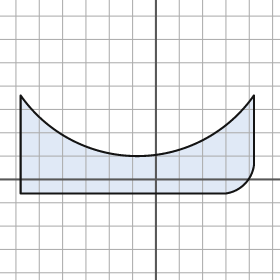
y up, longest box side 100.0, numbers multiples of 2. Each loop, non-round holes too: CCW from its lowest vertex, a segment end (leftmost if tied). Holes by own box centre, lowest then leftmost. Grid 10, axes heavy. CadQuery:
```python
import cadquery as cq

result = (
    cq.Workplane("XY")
    .moveTo(-58.0, -6.0)
    .lineTo(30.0, -6.0)
    .threePointArc((38.0, -2.0), (42.0, 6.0))
    .lineTo(42.0, 36.0)
    .threePointArc((-8.0, 10.0), (-58.0, 36.0))
    .close()
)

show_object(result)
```